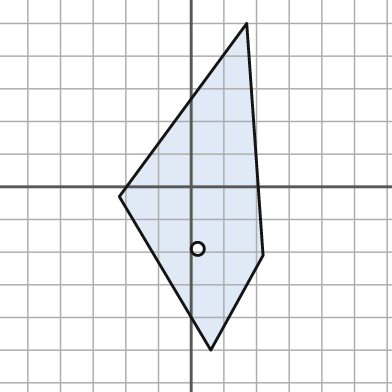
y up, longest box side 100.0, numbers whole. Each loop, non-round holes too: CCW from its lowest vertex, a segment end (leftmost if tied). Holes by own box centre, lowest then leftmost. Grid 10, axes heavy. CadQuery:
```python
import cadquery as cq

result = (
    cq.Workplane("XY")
    .moveTo(6.0, -50.0)
    .lineTo(22.0, -21.0)
    .lineTo(17.0, 50.0)
    .lineTo(-22.0, -3.0)
    .close()
    .moveTo(2.0, -19.0)
    .circle(2.0)
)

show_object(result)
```